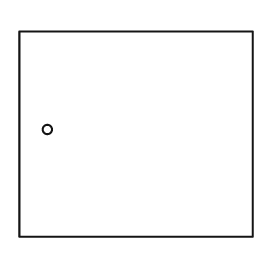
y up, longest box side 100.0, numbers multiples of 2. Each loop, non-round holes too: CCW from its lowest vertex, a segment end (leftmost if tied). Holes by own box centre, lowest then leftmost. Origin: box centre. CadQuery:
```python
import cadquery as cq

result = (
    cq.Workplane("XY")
    .moveTo(-50.0, -44.0)
    .lineTo(50.0, -44.0)
    .lineTo(50.0, 44.0)
    .lineTo(-50.0, 44.0)
    .close()
    .moveTo(-38.0, 2.0)
    .circle(2.0)
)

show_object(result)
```